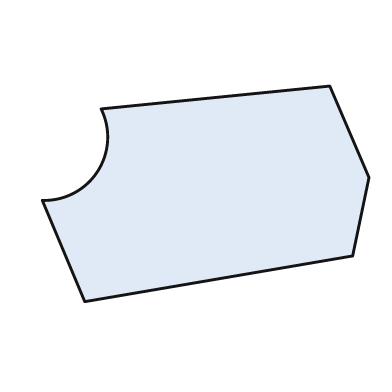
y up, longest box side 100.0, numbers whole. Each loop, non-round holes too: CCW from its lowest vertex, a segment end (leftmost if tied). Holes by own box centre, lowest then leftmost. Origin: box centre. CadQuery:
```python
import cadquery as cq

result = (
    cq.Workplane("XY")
    .moveTo(-37.0, -33.0)
    .lineTo(45.0, -19.0)
    .lineTo(50.0, 5.0)
    .lineTo(38.0, 33.0)
    .lineTo(-32.0, 26.0)
    .threePointArc((-33.0, 7.0), (-50.0, -2.0))
    .close()
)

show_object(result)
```